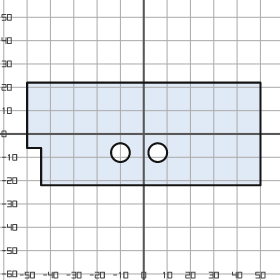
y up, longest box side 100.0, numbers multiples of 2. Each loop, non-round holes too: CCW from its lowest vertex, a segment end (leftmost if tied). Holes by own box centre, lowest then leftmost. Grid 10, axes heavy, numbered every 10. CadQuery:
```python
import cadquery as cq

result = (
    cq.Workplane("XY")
    .moveTo(-44.0, -22.0)
    .lineTo(50.0, -22.0)
    .lineTo(50.0, 22.0)
    .lineTo(-50.0, 22.0)
    .lineTo(-50.0, -6.0)
    .lineTo(-44.0, -6.0)
    .close()
    .moveTo(-10.0, -8.0)
    .circle(4.0)
    .moveTo(6.0, -8.0)
    .circle(4.0)
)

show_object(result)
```